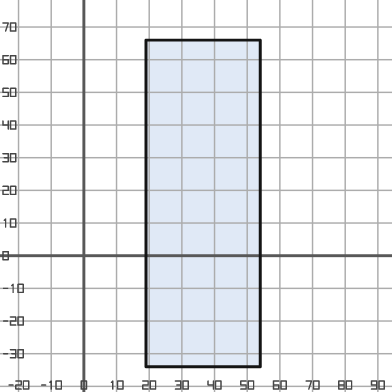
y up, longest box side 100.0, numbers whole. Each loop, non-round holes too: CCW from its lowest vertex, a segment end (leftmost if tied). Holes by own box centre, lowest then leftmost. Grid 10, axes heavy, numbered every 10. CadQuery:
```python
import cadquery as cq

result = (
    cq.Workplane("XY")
    .moveTo(19.0, -34.0)
    .lineTo(54.0, -34.0)
    .lineTo(54.0, 66.0)
    .lineTo(19.0, 66.0)
    .close()
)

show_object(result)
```